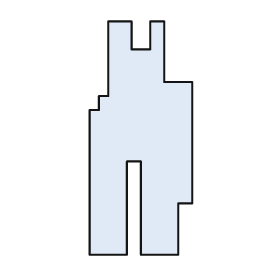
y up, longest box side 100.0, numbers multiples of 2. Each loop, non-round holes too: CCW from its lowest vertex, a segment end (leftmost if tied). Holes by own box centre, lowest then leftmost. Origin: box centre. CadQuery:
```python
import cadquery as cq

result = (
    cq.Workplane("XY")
    .moveTo(-22.0, -50.0)
    .lineTo(-6.0, -50.0)
    .lineTo(-6.0, -10.0)
    .lineTo(0.0, -10.0)
    .lineTo(0.0, -50.0)
    .lineTo(16.0, -50.0)
    .lineTo(16.0, -28.0)
    .lineTo(22.0, -28.0)
    .lineTo(22.0, 24.0)
    .lineTo(10.0, 24.0)
    .lineTo(10.0, 50.0)
    .lineTo(4.0, 50.0)
    .lineTo(4.0, 38.0)
    .lineTo(-4.0, 38.0)
    .lineTo(-4.0, 50.0)
    .lineTo(-14.0, 50.0)
    .lineTo(-14.0, 18.0)
    .lineTo(-18.0, 18.0)
    .lineTo(-18.0, 12.0)
    .lineTo(-22.0, 12.0)
    .close()
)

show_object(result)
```